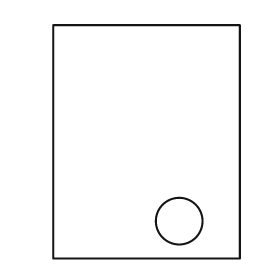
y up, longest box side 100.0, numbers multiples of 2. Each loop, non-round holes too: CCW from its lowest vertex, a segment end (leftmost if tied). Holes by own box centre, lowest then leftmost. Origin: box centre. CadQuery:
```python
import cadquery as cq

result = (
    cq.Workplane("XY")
    .moveTo(-40.0, -50.0)
    .lineTo(40.0, -50.0)
    .lineTo(40.0, 50.0)
    .lineTo(-40.0, 50.0)
    .close()
    .moveTo(14.0, -34.0)
    .circle(10.0)
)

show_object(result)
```